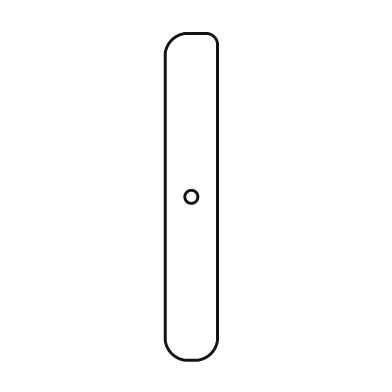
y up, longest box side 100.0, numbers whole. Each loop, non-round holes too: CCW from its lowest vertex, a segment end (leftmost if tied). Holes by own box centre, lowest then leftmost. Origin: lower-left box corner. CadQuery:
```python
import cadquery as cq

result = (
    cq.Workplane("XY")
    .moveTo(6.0, 0.0)
    .lineTo(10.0, 0.0)
    .threePointArc((14.0, 2.0), (16.0, 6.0))
    .lineTo(16.0, 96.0)
    .threePointArc((15.0, 99.0), (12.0, 100.0))
    .lineTo(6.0, 100.0)
    .threePointArc((2.0, 98.0), (0.0, 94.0))
    .lineTo(0.0, 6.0)
    .threePointArc((2.0, 2.0), (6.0, 0.0))
    .close()
    .moveTo(8.0, 50.0)
    .circle(2.0)
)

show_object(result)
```